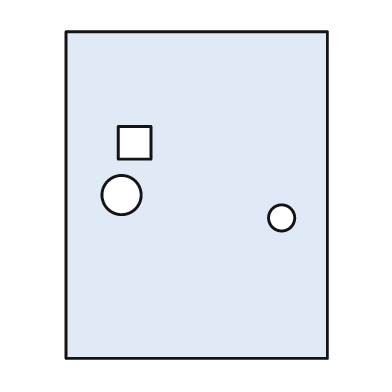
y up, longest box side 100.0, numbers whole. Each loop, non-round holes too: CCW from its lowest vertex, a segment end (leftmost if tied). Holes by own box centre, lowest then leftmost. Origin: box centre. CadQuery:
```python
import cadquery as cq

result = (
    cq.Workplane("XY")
    .moveTo(-40.0, -50.0)
    .lineTo(40.0, -50.0)
    .lineTo(40.0, 50.0)
    .lineTo(-40.0, 50.0)
    .close()
    .moveTo(26.0, -7.0)
    .circle(4.0)
    .moveTo(-23.0, 0.0)
    .circle(6.0)
    .moveTo(-24.0, 11.0)
    .lineTo(-14.0, 11.0)
    .lineTo(-14.0, 21.0)
    .lineTo(-24.0, 21.0)
    .close()
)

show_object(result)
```